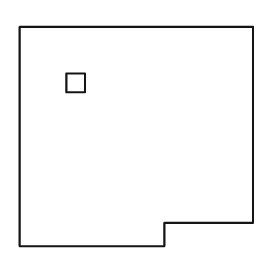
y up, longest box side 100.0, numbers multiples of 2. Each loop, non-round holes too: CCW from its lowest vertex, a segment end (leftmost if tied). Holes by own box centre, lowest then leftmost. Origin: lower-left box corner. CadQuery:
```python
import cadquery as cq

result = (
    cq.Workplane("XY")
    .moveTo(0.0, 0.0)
    .lineTo(62.0, 0.0)
    .lineTo(62.0, 10.0)
    .lineTo(100.0, 10.0)
    .lineTo(100.0, 94.0)
    .lineTo(0.0, 94.0)
    .close()
    .moveTo(20.0, 66.0)
    .lineTo(28.0, 66.0)
    .lineTo(28.0, 74.0)
    .lineTo(20.0, 74.0)
    .close()
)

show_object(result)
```